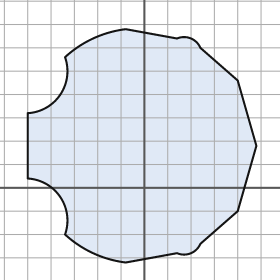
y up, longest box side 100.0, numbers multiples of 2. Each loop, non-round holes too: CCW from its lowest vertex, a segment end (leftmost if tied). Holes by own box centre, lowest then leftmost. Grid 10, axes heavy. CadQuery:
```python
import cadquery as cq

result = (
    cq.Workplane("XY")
    .moveTo(-8.0, -32.0)
    .lineTo(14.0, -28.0)
    .threePointArc((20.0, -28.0), (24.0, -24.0))
    .lineTo(40.0, -10.0)
    .lineTo(48.0, 18.0)
    .lineTo(40.0, 46.0)
    .lineTo(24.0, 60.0)
    .threePointArc((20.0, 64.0), (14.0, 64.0))
    .lineTo(-8.0, 68.0)
    .threePointArc((-22.0, 64.0), (-34.0, 56.0))
    .threePointArc((-36.0, 40.0), (-50.0, 32.0))
    .lineTo(-50.0, 4.0)
    .threePointArc((-36.0, -4.0), (-34.0, -20.0))
    .threePointArc((-22.0, -28.0), (-8.0, -32.0))
    .close()
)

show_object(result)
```